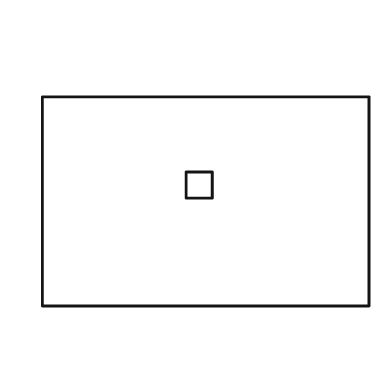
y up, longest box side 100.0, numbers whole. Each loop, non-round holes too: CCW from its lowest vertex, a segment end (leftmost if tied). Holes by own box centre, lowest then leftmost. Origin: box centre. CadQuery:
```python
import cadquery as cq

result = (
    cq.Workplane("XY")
    .moveTo(-50.0, -32.0)
    .lineTo(50.0, -32.0)
    .lineTo(50.0, 32.0)
    .lineTo(-50.0, 32.0)
    .close()
    .moveTo(-6.0, 1.0)
    .lineTo(2.0, 1.0)
    .lineTo(2.0, 9.0)
    .lineTo(-6.0, 9.0)
    .close()
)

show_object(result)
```